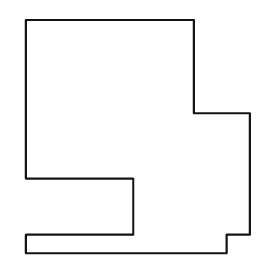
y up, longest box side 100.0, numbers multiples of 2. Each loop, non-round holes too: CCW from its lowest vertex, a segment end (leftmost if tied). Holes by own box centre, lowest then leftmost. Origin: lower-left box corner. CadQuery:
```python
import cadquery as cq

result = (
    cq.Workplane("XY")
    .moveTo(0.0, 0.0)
    .lineTo(86.0, 0.0)
    .lineTo(86.0, 8.0)
    .lineTo(96.0, 8.0)
    .lineTo(96.0, 60.0)
    .lineTo(72.0, 60.0)
    .lineTo(72.0, 100.0)
    .lineTo(0.0, 100.0)
    .lineTo(0.0, 32.0)
    .lineTo(46.0, 32.0)
    .lineTo(46.0, 8.0)
    .lineTo(0.0, 8.0)
    .close()
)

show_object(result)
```